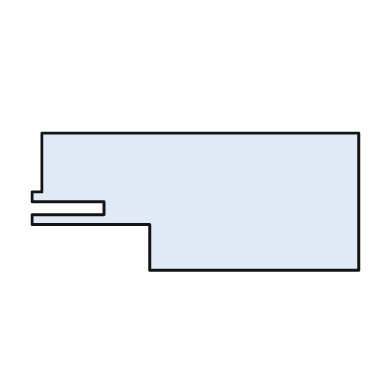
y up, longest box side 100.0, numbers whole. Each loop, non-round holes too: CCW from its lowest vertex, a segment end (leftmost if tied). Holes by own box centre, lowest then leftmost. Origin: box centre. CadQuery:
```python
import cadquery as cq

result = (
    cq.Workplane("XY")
    .moveTo(-14.0, -21.0)
    .lineTo(50.0, -21.0)
    .lineTo(50.0, 21.0)
    .lineTo(-47.0, 21.0)
    .lineTo(-47.0, 3.0)
    .lineTo(-50.0, 3.0)
    .lineTo(-50.0, 0.0)
    .lineTo(-28.0, 0.0)
    .lineTo(-28.0, -4.0)
    .lineTo(-50.0, -4.0)
    .lineTo(-50.0, -7.0)
    .lineTo(-14.0, -7.0)
    .close()
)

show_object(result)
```